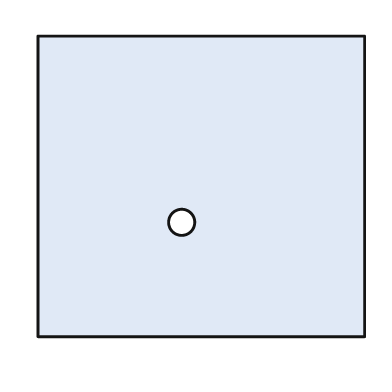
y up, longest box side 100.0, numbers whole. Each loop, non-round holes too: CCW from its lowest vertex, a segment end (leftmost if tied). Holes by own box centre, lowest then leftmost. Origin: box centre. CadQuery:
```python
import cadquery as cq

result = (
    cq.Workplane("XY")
    .moveTo(-50.0, -46.0)
    .lineTo(50.0, -46.0)
    .lineTo(50.0, 46.0)
    .lineTo(-50.0, 46.0)
    .close()
    .moveTo(-6.0, -11.0)
    .circle(4.0)
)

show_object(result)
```